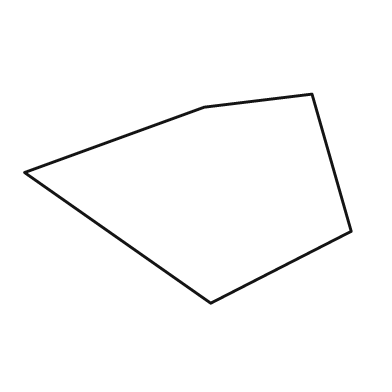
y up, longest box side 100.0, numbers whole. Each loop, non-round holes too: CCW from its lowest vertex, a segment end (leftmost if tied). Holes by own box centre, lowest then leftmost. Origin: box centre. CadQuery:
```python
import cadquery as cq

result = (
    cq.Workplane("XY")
    .moveTo(7.0, -32.0)
    .lineTo(50.0, -10.0)
    .lineTo(38.0, 32.0)
    .lineTo(5.0, 28.0)
    .lineTo(-50.0, 8.0)
    .close()
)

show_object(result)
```